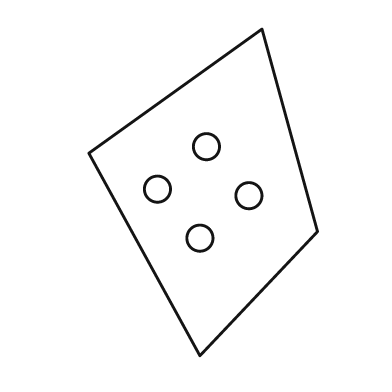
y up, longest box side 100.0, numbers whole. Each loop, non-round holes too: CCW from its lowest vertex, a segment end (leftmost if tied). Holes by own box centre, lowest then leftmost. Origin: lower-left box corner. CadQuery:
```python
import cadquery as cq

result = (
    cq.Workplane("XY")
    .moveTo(34.0, 0.0)
    .lineTo(70.0, 38.0)
    .lineTo(53.0, 100.0)
    .lineTo(0.0, 62.0)
    .close()
    .moveTo(34.0, 36.0)
    .circle(4.0)
    .moveTo(49.0, 49.0)
    .circle(4.0)
    .moveTo(21.0, 51.0)
    .circle(4.0)
    .moveTo(36.0, 64.0)
    .circle(4.0)
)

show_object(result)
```